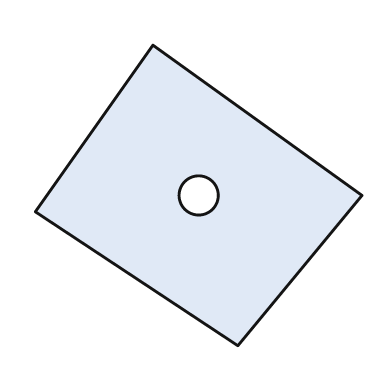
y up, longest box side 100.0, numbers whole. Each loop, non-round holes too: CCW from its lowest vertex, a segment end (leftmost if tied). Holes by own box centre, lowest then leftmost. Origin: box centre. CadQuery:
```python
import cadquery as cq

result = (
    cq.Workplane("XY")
    .moveTo(12.0, -46.0)
    .lineTo(50.0, 0.0)
    .lineTo(-14.0, 46.0)
    .lineTo(-50.0, -5.0)
    .close()
    .moveTo(0.0, 0.0)
    .circle(6.0)
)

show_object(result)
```